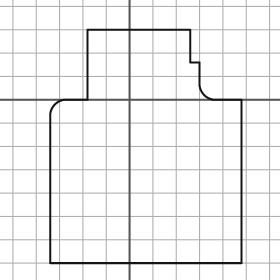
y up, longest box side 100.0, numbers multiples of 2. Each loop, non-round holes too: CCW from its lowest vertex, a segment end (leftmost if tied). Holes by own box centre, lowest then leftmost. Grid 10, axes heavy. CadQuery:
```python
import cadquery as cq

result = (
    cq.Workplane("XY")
    .moveTo(-34.0, -70.0)
    .lineTo(48.0, -70.0)
    .lineTo(48.0, 0.0)
    .lineTo(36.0, 0.0)
    .threePointArc((32.0, 2.0), (30.0, 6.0))
    .lineTo(30.0, 16.0)
    .lineTo(26.0, 16.0)
    .lineTo(26.0, 30.0)
    .lineTo(-18.0, 30.0)
    .lineTo(-18.0, 0.0)
    .lineTo(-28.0, 0.0)
    .threePointArc((-32.0, -2.0), (-34.0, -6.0))
    .close()
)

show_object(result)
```